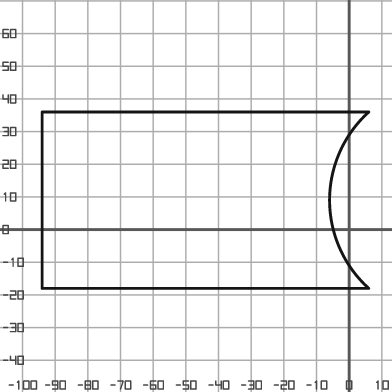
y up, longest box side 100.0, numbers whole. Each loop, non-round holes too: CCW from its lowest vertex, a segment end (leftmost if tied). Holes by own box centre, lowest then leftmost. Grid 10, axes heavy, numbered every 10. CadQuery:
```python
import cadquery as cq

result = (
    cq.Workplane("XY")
    .moveTo(-94.0, -18.0)
    .lineTo(6.0, -18.0)
    .threePointArc((-6.0, 9.0), (6.0, 36.0))
    .lineTo(-94.0, 36.0)
    .close()
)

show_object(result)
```